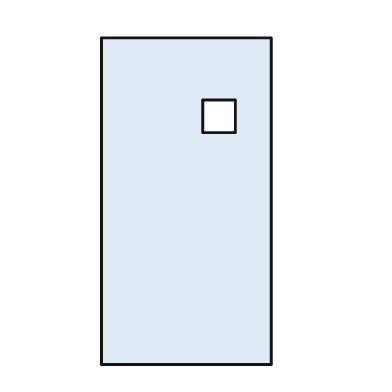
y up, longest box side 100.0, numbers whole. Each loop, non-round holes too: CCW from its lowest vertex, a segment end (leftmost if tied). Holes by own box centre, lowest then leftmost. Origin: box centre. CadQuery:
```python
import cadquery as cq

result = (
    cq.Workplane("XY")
    .moveTo(-26.0, -50.0)
    .lineTo(26.0, -50.0)
    .lineTo(26.0, 50.0)
    .lineTo(-26.0, 50.0)
    .close()
    .moveTo(5.0, 21.0)
    .lineTo(15.0, 21.0)
    .lineTo(15.0, 31.0)
    .lineTo(5.0, 31.0)
    .close()
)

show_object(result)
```